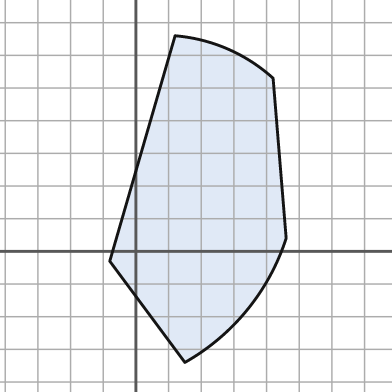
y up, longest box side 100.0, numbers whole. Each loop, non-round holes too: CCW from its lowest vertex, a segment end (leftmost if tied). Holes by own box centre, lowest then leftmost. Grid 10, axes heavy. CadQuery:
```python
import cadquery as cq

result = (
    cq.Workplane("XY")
    .moveTo(15.0, -34.0)
    .threePointArc((34.0, -18.0), (46.0, 4.0))
    .lineTo(42.0, 53.0)
    .threePointArc((28.0, 62.0), (12.0, 66.0))
    .lineTo(-8.0, -3.0)
    .close()
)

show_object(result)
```